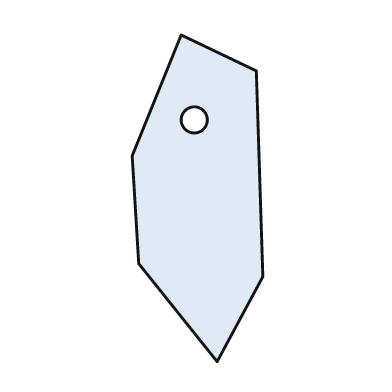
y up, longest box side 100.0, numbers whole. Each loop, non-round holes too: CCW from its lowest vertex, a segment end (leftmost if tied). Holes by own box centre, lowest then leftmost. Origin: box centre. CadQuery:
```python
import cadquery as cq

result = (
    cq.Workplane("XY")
    .moveTo(6.0, -50.0)
    .lineTo(20.0, -24.0)
    .lineTo(18.0, 39.0)
    .lineTo(-5.0, 50.0)
    .lineTo(-20.0, 13.0)
    .lineTo(-18.0, -20.0)
    .close()
    .moveTo(-1.0, 24.0)
    .circle(4.0)
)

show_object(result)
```